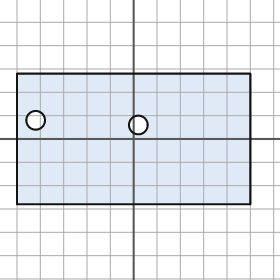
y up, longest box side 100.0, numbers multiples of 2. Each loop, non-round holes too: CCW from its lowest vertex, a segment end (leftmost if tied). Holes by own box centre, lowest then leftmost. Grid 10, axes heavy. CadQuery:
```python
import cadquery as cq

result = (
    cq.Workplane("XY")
    .moveTo(-50.0, -28.0)
    .lineTo(50.0, -28.0)
    .lineTo(50.0, 28.0)
    .lineTo(-50.0, 28.0)
    .close()
    .moveTo(2.0, 6.0)
    .circle(4.0)
    .moveTo(-42.0, 8.0)
    .circle(4.0)
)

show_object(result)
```